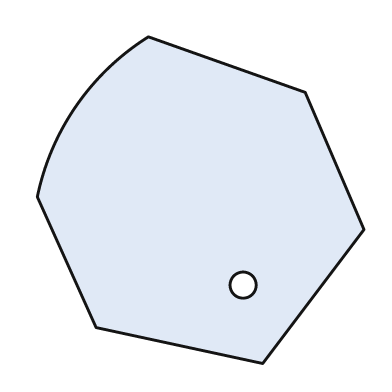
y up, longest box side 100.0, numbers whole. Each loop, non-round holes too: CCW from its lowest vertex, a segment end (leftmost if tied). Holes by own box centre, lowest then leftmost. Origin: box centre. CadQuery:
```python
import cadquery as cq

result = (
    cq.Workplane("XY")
    .moveTo(19.0, -50.0)
    .lineTo(50.0, -9.0)
    .lineTo(32.0, 33.0)
    .lineTo(-16.0, 50.0)
    .threePointArc((-38.0, 29.0), (-50.0, 1.0))
    .lineTo(-32.0, -39.0)
    .close()
    .moveTo(13.0, -26.0)
    .circle(4.0)
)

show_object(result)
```